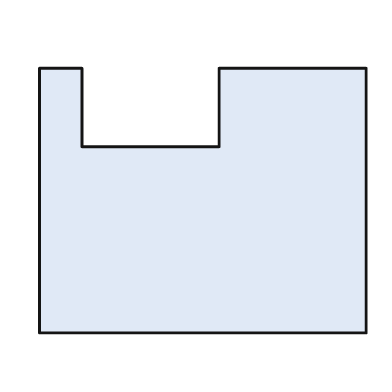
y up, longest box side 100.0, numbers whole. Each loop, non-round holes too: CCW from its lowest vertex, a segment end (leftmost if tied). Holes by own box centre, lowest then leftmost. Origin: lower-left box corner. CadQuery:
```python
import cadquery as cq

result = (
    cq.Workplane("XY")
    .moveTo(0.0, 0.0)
    .lineTo(100.0, 0.0)
    .lineTo(100.0, 81.0)
    .lineTo(55.0, 81.0)
    .lineTo(55.0, 57.0)
    .lineTo(13.0, 57.0)
    .lineTo(13.0, 81.0)
    .lineTo(0.0, 81.0)
    .close()
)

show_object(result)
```